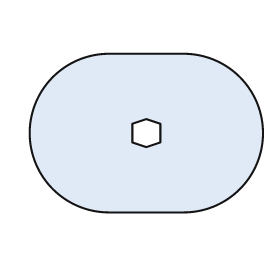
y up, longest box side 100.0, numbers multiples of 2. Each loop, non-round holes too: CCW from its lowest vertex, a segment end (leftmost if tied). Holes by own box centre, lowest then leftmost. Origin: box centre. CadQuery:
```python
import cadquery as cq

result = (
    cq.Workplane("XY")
    .moveTo(-16.0, -34.0)
    .lineTo(16.0, -34.0)
    .threePointArc((50.0, 0.0), (16.0, 34.0))
    .lineTo(-16.0, 34.0)
    .threePointArc((-50.0, 0.0), (-16.0, -34.0))
    .close()
    .moveTo(0.0, -6.0)
    .lineTo(6.0, -4.0)
    .lineTo(6.0, 4.0)
    .lineTo(0.0, 6.0)
    .lineTo(-6.0, 4.0)
    .lineTo(-6.0, -4.0)
    .close()
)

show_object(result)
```